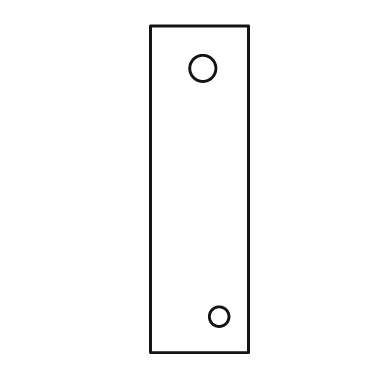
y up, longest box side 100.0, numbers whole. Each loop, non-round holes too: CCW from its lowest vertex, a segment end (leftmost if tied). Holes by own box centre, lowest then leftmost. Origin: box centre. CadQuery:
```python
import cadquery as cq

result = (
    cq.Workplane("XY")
    .moveTo(-15.0, -50.0)
    .lineTo(15.0, -50.0)
    .lineTo(15.0, 50.0)
    .lineTo(-15.0, 50.0)
    .close()
    .moveTo(6.0, -39.0)
    .circle(3.0)
    .moveTo(1.0, 37.0)
    .circle(4.0)
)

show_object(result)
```